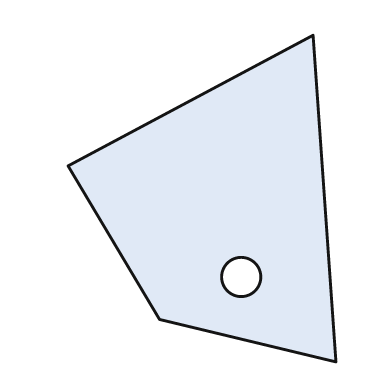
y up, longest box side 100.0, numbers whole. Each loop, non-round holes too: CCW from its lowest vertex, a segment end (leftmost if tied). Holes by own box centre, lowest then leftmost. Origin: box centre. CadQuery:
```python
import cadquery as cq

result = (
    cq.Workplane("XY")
    .moveTo(41.0, -50.0)
    .lineTo(34.0, 50.0)
    .lineTo(-41.0, 10.0)
    .lineTo(-13.0, -37.0)
    .close()
    .moveTo(12.0, -24.0)
    .circle(6.0)
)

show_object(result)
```